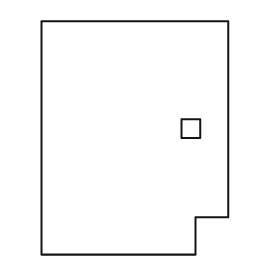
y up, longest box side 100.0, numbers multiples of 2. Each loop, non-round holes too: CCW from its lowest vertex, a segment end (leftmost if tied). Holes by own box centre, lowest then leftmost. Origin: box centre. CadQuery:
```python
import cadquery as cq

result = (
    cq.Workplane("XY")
    .moveTo(-40.0, -50.0)
    .lineTo(26.0, -50.0)
    .lineTo(26.0, -34.0)
    .lineTo(40.0, -34.0)
    .lineTo(40.0, 50.0)
    .lineTo(-40.0, 50.0)
    .close()
    .moveTo(20.0, 0.0)
    .lineTo(28.0, 0.0)
    .lineTo(28.0, 8.0)
    .lineTo(20.0, 8.0)
    .close()
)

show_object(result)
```